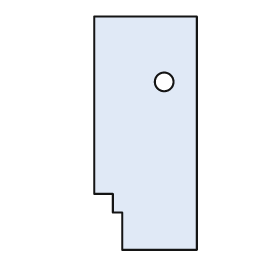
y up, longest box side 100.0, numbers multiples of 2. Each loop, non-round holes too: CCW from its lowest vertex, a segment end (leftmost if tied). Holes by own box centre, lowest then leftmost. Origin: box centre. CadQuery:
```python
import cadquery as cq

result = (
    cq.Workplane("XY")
    .moveTo(-10.0, -50.0)
    .lineTo(22.0, -50.0)
    .lineTo(22.0, 50.0)
    .lineTo(-22.0, 50.0)
    .lineTo(-22.0, -26.0)
    .lineTo(-14.0, -26.0)
    .lineTo(-14.0, -34.0)
    .lineTo(-10.0, -34.0)
    .close()
    .moveTo(8.0, 22.0)
    .circle(4.0)
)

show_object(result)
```